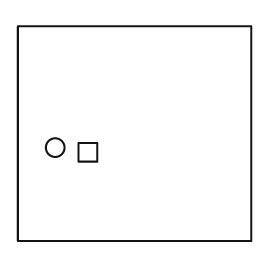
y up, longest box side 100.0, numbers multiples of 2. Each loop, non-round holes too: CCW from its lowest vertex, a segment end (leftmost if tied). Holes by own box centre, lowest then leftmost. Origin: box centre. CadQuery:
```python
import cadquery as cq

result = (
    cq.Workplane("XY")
    .moveTo(-50.0, -46.0)
    .lineTo(50.0, -46.0)
    .lineTo(50.0, 46.0)
    .lineTo(-50.0, 46.0)
    .close()
    .moveTo(-24.0, -12.0)
    .lineTo(-16.0, -12.0)
    .lineTo(-16.0, -4.0)
    .lineTo(-24.0, -4.0)
    .close()
    .moveTo(-34.0, -6.0)
    .circle(4.0)
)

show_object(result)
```